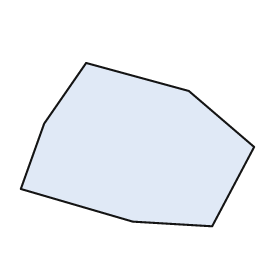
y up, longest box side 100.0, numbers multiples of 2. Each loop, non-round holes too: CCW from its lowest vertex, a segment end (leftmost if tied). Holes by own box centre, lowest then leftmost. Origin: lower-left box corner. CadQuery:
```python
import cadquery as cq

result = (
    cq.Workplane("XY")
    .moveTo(82.0, 0.0)
    .lineTo(100.0, 34.0)
    .lineTo(72.0, 58.0)
    .lineTo(28.0, 70.0)
    .lineTo(10.0, 44.0)
    .lineTo(0.0, 16.0)
    .lineTo(48.0, 2.0)
    .close()
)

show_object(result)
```